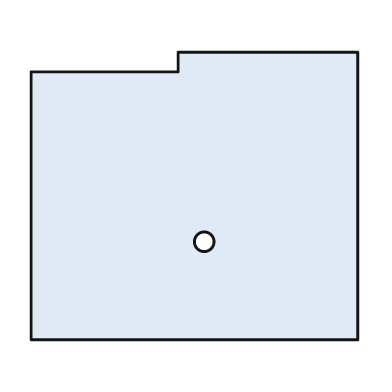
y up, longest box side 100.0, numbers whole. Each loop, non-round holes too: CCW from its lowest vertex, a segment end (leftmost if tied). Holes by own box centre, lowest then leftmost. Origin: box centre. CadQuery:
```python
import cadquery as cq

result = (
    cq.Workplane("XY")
    .moveTo(-50.0, -44.0)
    .lineTo(50.0, -44.0)
    .lineTo(50.0, 44.0)
    .lineTo(-5.0, 44.0)
    .lineTo(-5.0, 38.0)
    .lineTo(-50.0, 38.0)
    .close()
    .moveTo(3.0, -14.0)
    .circle(3.0)
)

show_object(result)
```